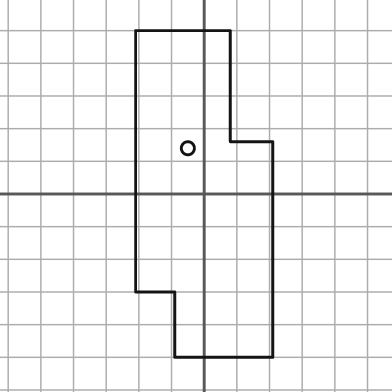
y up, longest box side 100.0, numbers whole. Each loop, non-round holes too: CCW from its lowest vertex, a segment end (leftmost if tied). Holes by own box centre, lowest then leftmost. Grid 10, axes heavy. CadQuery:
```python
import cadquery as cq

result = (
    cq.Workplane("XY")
    .moveTo(-9.0, -50.0)
    .lineTo(21.0, -50.0)
    .lineTo(21.0, 16.0)
    .lineTo(8.0, 16.0)
    .lineTo(8.0, 50.0)
    .lineTo(-21.0, 50.0)
    .lineTo(-21.0, -30.0)
    .lineTo(-9.0, -30.0)
    .close()
    .moveTo(-5.0, 14.0)
    .circle(2.0)
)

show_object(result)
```